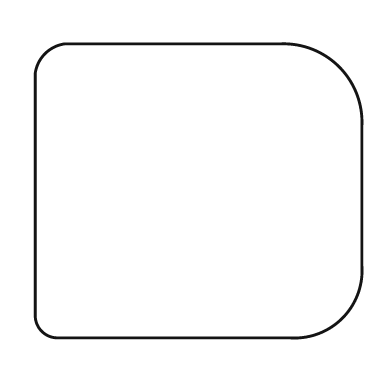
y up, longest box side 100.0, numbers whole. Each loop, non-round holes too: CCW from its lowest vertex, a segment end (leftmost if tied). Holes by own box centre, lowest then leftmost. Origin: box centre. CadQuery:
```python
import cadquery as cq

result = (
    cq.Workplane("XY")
    .moveTo(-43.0, -45.0)
    .lineTo(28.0, -45.0)
    .threePointArc((44.0, -39.0), (50.0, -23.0))
    .lineTo(50.0, 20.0)
    .threePointArc((43.0, 38.0), (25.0, 45.0))
    .lineTo(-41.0, 45.0)
    .threePointArc((-47.0, 42.0), (-50.0, 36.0))
    .lineTo(-50.0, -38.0)
    .threePointArc((-48.0, -43.0), (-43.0, -45.0))
    .close()
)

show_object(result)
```